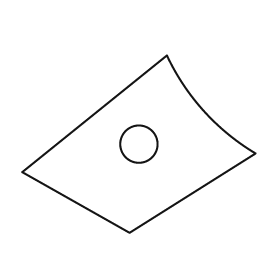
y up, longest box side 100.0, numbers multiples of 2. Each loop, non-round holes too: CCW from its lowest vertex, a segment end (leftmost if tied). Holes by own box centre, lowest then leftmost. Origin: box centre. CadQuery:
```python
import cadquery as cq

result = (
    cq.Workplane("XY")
    .moveTo(-4.0, -38.0)
    .lineTo(50.0, -4.0)
    .threePointArc((28.0, 14.0), (12.0, 38.0))
    .lineTo(-50.0, -12.0)
    .close()
    .moveTo(0.0, 0.0)
    .circle(8.0)
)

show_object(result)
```